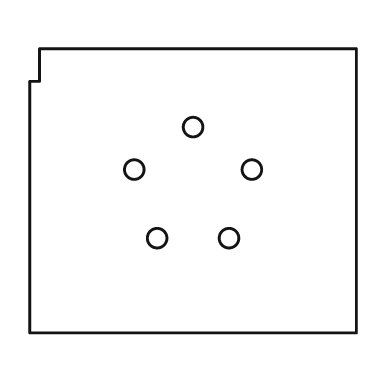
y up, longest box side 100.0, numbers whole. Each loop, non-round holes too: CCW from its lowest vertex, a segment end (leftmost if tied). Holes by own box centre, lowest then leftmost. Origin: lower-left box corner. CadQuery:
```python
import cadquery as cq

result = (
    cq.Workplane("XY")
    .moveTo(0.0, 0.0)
    .lineTo(100.0, 0.0)
    .lineTo(100.0, 87.0)
    .lineTo(3.0, 87.0)
    .lineTo(3.0, 77.0)
    .lineTo(0.0, 77.0)
    .close()
    .moveTo(39.0, 29.0)
    .circle(3.0)
    .moveTo(61.0, 29.0)
    .circle(3.0)
    .moveTo(32.0, 50.0)
    .circle(3.0)
    .moveTo(68.0, 50.0)
    .circle(3.0)
    .moveTo(50.0, 63.0)
    .circle(3.0)
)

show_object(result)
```